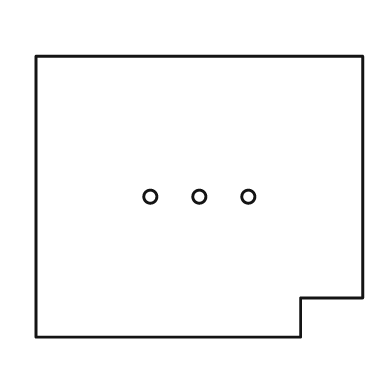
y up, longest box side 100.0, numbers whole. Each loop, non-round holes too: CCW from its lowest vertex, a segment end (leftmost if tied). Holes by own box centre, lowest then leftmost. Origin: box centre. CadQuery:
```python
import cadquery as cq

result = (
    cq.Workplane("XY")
    .moveTo(-50.0, -43.0)
    .lineTo(31.0, -43.0)
    .lineTo(31.0, -31.0)
    .lineTo(50.0, -31.0)
    .lineTo(50.0, 43.0)
    .lineTo(-50.0, 43.0)
    .close()
    .moveTo(-15.0, 0.0)
    .circle(2.0)
    .moveTo(0.0, 0.0)
    .circle(2.0)
    .moveTo(15.0, 0.0)
    .circle(2.0)
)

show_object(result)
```